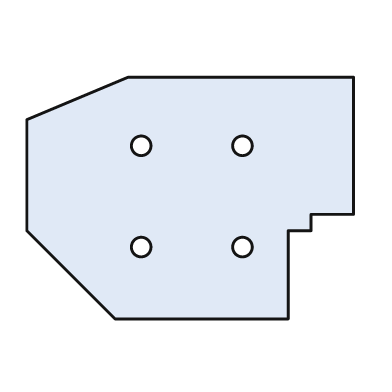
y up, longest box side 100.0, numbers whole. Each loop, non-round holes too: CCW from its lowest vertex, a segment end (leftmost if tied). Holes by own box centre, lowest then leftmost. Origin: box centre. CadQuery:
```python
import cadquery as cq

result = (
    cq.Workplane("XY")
    .moveTo(-23.0, -37.0)
    .lineTo(30.0, -37.0)
    .lineTo(30.0, -10.0)
    .lineTo(37.0, -10.0)
    .lineTo(37.0, -5.0)
    .lineTo(50.0, -5.0)
    .lineTo(50.0, 37.0)
    .lineTo(-19.0, 37.0)
    .lineTo(-50.0, 24.0)
    .lineTo(-50.0, -10.0)
    .close()
    .moveTo(-15.0, -15.0)
    .circle(3.0)
    .moveTo(16.0, -15.0)
    .circle(3.0)
    .moveTo(-15.0, 16.0)
    .circle(3.0)
    .moveTo(16.0, 16.0)
    .circle(3.0)
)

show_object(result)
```